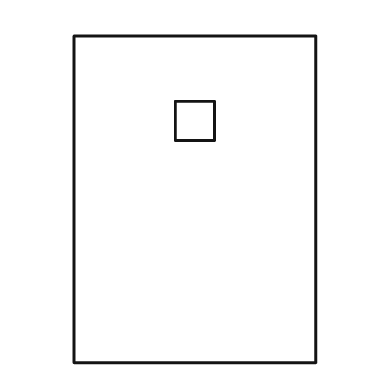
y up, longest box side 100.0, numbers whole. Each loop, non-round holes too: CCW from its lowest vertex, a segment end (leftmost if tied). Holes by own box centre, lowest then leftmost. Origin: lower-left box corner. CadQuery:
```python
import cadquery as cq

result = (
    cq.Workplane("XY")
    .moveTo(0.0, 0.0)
    .lineTo(74.0, 0.0)
    .lineTo(74.0, 100.0)
    .lineTo(0.0, 100.0)
    .close()
    .moveTo(31.0, 68.0)
    .lineTo(43.0, 68.0)
    .lineTo(43.0, 80.0)
    .lineTo(31.0, 80.0)
    .close()
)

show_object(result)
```